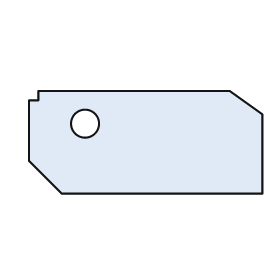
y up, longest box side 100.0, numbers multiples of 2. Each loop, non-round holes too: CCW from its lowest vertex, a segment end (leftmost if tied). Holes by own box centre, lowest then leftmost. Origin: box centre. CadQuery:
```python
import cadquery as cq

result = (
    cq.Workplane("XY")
    .moveTo(-36.0, -22.0)
    .lineTo(50.0, -22.0)
    .lineTo(50.0, 12.0)
    .lineTo(36.0, 22.0)
    .lineTo(-46.0, 22.0)
    .lineTo(-46.0, 18.0)
    .lineTo(-50.0, 18.0)
    .lineTo(-50.0, -8.0)
    .close()
    .moveTo(-26.0, 8.0)
    .circle(6.0)
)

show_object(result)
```